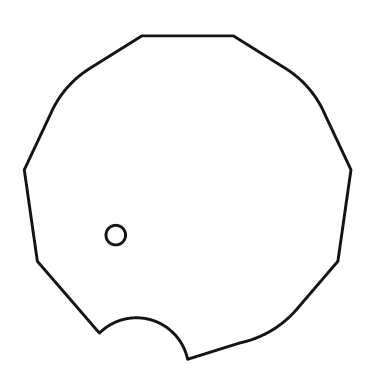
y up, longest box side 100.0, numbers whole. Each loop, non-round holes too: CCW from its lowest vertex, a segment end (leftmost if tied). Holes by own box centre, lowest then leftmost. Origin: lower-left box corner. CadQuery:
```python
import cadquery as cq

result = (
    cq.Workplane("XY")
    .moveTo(50.0, 0.0)
    .lineTo(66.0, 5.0)
    .threePointArc((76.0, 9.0), (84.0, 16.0))
    .lineTo(96.0, 30.0)
    .lineTo(100.0, 58.0)
    .lineTo(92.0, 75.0)
    .threePointArc((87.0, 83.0), (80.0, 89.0))
    .lineTo(64.0, 99.0)
    .lineTo(36.0, 99.0)
    .lineTo(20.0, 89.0)
    .threePointArc((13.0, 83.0), (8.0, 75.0))
    .lineTo(0.0, 58.0)
    .lineTo(4.0, 30.0)
    .lineTo(23.0, 8.0)
    .threePointArc((39.0, 12.0), (50.0, 0.0))
    .close()
    .moveTo(28.0, 38.0)
    .circle(3.0)
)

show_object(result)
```